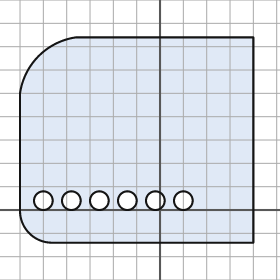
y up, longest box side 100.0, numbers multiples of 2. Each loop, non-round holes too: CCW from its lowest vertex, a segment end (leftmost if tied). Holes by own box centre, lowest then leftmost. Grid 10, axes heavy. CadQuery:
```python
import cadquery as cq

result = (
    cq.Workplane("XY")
    .moveTo(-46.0, -14.0)
    .lineTo(40.0, -14.0)
    .lineTo(40.0, 74.0)
    .lineTo(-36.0, 74.0)
    .threePointArc((-52.0, 66.0), (-60.0, 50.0))
    .lineTo(-60.0, 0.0)
    .threePointArc((-56.0, -10.0), (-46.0, -14.0))
    .close()
    .moveTo(-50.0, 4.0)
    .circle(4.0)
    .moveTo(-38.0, 4.0)
    .circle(4.0)
    .moveTo(-26.0, 4.0)
    .circle(4.0)
    .moveTo(-14.0, 4.0)
    .circle(4.0)
    .moveTo(-2.0, 4.0)
    .circle(4.0)
    .moveTo(10.0, 4.0)
    .circle(4.0)
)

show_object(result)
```